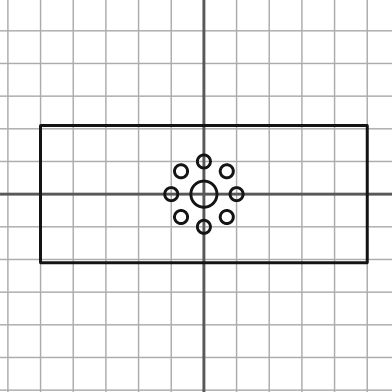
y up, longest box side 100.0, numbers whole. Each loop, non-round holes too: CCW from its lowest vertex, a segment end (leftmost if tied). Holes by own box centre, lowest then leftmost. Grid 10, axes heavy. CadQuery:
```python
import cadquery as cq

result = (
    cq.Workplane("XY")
    .moveTo(-50.0, -21.0)
    .lineTo(50.0, -21.0)
    .lineTo(50.0, 21.0)
    .lineTo(-50.0, 21.0)
    .close()
    .moveTo(0.0, -10.0)
    .circle(2.0)
    .moveTo(-7.0, -7.0)
    .circle(2.0)
    .moveTo(7.0, -7.0)
    .circle(2.0)
    .moveTo(-10.0, 0.0)
    .circle(2.0)
    .moveTo(0.0, 0.0)
    .circle(4.0)
    .moveTo(10.0, 0.0)
    .circle(2.0)
    .moveTo(-7.0, 7.0)
    .circle(2.0)
    .moveTo(7.0, 7.0)
    .circle(2.0)
    .moveTo(0.0, 10.0)
    .circle(2.0)
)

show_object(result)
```